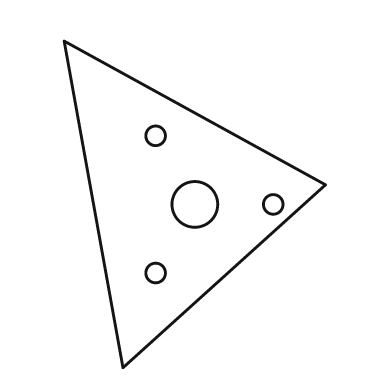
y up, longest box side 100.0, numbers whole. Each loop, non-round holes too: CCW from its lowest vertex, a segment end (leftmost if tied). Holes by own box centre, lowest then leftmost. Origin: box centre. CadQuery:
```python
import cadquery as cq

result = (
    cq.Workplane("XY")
    .moveTo(-22.0, -50.0)
    .lineTo(40.0, 6.0)
    .lineTo(-40.0, 50.0)
    .close()
    .moveTo(-12.0, -21.0)
    .circle(3.0)
    .moveTo(0.0, 0.0)
    .circle(7.0)
    .moveTo(24.0, 0.0)
    .circle(3.0)
    .moveTo(-12.0, 21.0)
    .circle(3.0)
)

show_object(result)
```